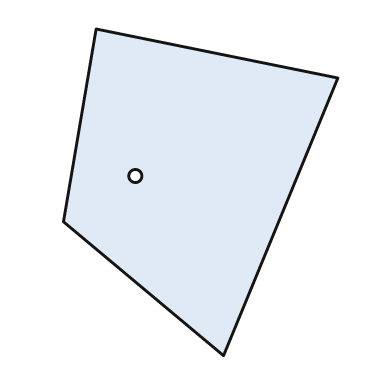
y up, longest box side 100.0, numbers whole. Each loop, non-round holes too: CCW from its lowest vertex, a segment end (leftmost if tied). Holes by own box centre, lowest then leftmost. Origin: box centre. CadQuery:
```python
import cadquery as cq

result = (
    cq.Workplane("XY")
    .moveTo(7.0, -50.0)
    .lineTo(42.0, 35.0)
    .lineTo(-32.0, 50.0)
    .lineTo(-42.0, -9.0)
    .close()
    .moveTo(-20.0, 5.0)
    .circle(2.0)
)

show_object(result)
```